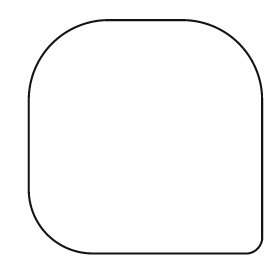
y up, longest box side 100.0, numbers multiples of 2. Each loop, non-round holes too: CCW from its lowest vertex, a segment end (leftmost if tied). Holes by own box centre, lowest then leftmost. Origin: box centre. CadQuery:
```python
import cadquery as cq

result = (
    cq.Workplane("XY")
    .moveTo(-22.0, -50.0)
    .lineTo(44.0, -50.0)
    .threePointArc((48.0, -48.0), (50.0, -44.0))
    .lineTo(50.0, 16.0)
    .threePointArc((40.0, 40.0), (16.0, 50.0))
    .lineTo(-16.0, 50.0)
    .threePointArc((-40.0, 40.0), (-50.0, 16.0))
    .lineTo(-50.0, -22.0)
    .threePointArc((-42.0, -42.0), (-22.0, -50.0))
    .close()
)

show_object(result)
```